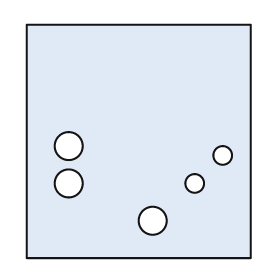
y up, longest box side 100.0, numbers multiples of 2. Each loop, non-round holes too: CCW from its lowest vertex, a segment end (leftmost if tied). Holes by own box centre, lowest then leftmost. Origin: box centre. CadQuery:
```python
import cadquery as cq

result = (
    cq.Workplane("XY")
    .moveTo(-48.0, -50.0)
    .lineTo(48.0, -50.0)
    .lineTo(48.0, 50.0)
    .lineTo(-48.0, 50.0)
    .close()
    .moveTo(6.0, -34.0)
    .circle(6.0)
    .moveTo(-30.0, -18.0)
    .circle(6.0)
    .moveTo(24.0, -18.0)
    .circle(4.0)
    .moveTo(36.0, -6.0)
    .circle(4.0)
    .moveTo(-30.0, -2.0)
    .circle(6.0)
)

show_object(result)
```